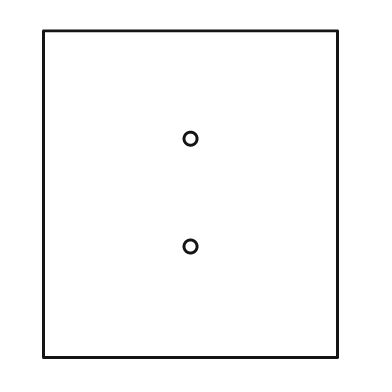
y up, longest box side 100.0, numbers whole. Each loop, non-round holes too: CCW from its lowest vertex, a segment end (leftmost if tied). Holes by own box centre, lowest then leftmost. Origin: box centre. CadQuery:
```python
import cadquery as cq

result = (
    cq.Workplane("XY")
    .moveTo(-45.0, -50.0)
    .lineTo(45.0, -50.0)
    .lineTo(45.0, 50.0)
    .lineTo(-45.0, 50.0)
    .close()
    .moveTo(0.0, -16.0)
    .circle(2.0)
    .moveTo(0.0, 17.0)
    .circle(2.0)
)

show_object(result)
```